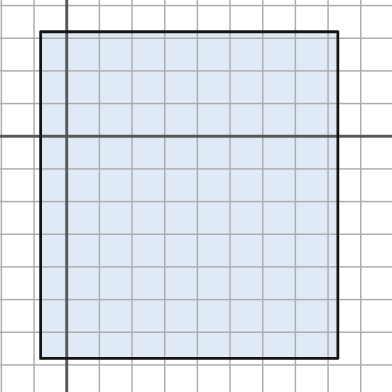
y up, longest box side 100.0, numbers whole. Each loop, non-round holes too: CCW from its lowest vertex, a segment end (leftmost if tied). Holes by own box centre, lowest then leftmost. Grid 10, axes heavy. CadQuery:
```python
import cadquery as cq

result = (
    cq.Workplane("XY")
    .moveTo(-8.0, -68.0)
    .lineTo(83.0, -68.0)
    .lineTo(83.0, 32.0)
    .lineTo(-8.0, 32.0)
    .close()
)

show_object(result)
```